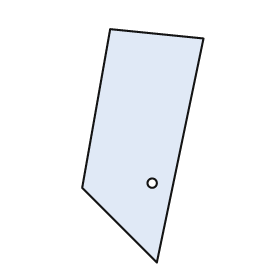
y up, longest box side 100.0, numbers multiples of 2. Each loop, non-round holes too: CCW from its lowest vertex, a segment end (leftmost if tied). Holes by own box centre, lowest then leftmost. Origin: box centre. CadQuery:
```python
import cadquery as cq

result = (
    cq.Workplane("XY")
    .moveTo(6.0, -50.0)
    .lineTo(26.0, 46.0)
    .lineTo(-14.0, 50.0)
    .lineTo(-26.0, -18.0)
    .close()
    .moveTo(4.0, -16.0)
    .circle(2.0)
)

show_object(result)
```